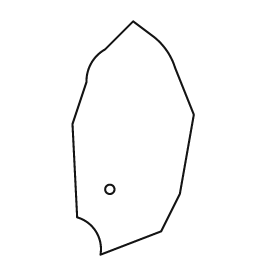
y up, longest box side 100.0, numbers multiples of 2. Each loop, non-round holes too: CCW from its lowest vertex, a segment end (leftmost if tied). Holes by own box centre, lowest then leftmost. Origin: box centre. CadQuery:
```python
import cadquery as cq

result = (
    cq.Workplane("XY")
    .moveTo(-14.0, -50.0)
    .lineTo(12.0, -40.0)
    .lineTo(20.0, -24.0)
    .lineTo(26.0, 10.0)
    .lineTo(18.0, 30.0)
    .threePointArc((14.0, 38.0), (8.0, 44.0))
    .lineTo(0.0, 50.0)
    .lineTo(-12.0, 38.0)
    .threePointArc((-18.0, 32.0), (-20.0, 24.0))
    .lineTo(-26.0, 6.0)
    .lineTo(-24.0, -34.0)
    .threePointArc((-16.0, -40.0), (-14.0, -50.0))
    .close()
    .moveTo(-10.0, -22.0)
    .circle(2.0)
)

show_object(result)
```